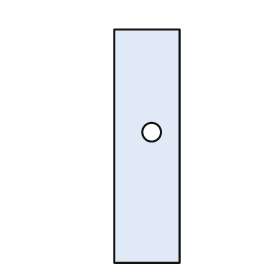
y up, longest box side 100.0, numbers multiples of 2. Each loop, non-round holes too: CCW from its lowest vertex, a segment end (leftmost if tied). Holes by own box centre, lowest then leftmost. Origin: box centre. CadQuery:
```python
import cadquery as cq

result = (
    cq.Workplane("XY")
    .moveTo(-14.0, -50.0)
    .lineTo(14.0, -50.0)
    .lineTo(14.0, 50.0)
    .lineTo(-14.0, 50.0)
    .close()
    .moveTo(2.0, 6.0)
    .circle(4.0)
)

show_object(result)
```